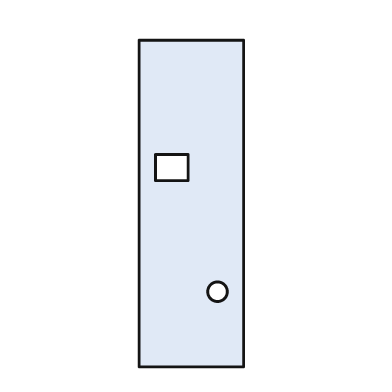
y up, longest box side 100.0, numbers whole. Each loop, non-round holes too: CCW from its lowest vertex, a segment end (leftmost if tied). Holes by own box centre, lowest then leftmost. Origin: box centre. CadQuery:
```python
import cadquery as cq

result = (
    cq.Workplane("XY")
    .moveTo(-16.0, -50.0)
    .lineTo(16.0, -50.0)
    .lineTo(16.0, 50.0)
    .lineTo(-16.0, 50.0)
    .close()
    .moveTo(8.0, -27.0)
    .circle(3.0)
    .moveTo(-11.0, 7.0)
    .lineTo(-1.0, 7.0)
    .lineTo(-1.0, 15.0)
    .lineTo(-11.0, 15.0)
    .close()
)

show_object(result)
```